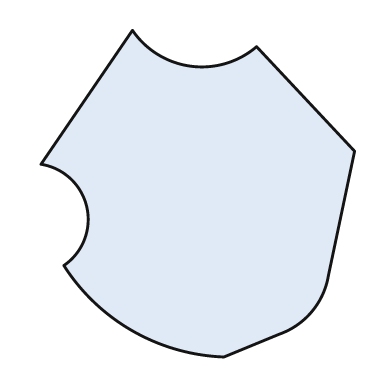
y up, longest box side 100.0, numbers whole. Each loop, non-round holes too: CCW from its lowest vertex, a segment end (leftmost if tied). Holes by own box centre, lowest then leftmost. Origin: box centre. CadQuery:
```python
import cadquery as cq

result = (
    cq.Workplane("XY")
    .moveTo(8.0, -50.0)
    .lineTo(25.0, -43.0)
    .threePointArc((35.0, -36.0), (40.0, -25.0))
    .lineTo(48.0, 13.0)
    .lineTo(18.0, 45.0)
    .threePointArc((-2.0, 39.0), (-20.0, 50.0))
    .lineTo(-48.0, 9.0)
    .threePointArc((-34.0, -4.0), (-41.0, -22.0))
    .threePointArc((-20.0, -42.0), (8.0, -50.0))
    .close()
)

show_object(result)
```